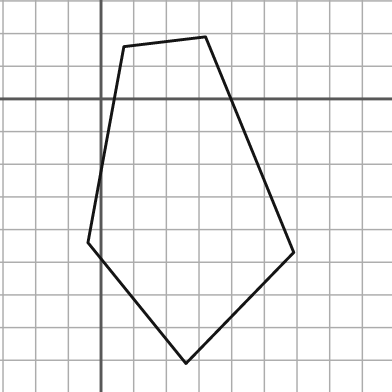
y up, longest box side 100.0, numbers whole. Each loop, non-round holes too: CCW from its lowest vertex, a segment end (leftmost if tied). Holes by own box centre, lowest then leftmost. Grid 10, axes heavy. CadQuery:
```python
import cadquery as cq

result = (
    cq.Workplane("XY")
    .moveTo(26.0, -81.0)
    .lineTo(59.0, -47.0)
    .lineTo(32.0, 19.0)
    .lineTo(7.0, 16.0)
    .lineTo(-4.0, -44.0)
    .close()
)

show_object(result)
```